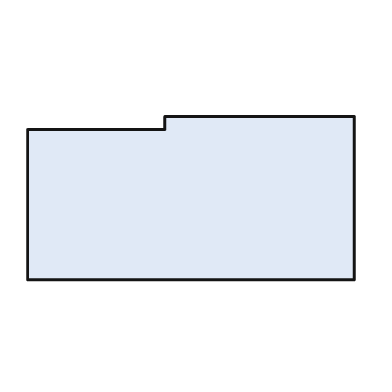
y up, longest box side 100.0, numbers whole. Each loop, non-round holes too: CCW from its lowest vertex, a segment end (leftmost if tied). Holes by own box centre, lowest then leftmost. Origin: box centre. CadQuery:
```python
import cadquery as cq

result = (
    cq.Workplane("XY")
    .moveTo(-50.0, -25.0)
    .lineTo(50.0, -25.0)
    .lineTo(50.0, 25.0)
    .lineTo(-8.0, 25.0)
    .lineTo(-8.0, 21.0)
    .lineTo(-50.0, 21.0)
    .close()
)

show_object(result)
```